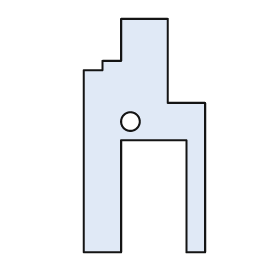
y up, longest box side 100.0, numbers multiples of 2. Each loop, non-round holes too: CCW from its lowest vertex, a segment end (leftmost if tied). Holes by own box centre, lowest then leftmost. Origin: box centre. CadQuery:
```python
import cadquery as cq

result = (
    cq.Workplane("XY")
    .moveTo(-26.0, -50.0)
    .lineTo(-10.0, -50.0)
    .lineTo(-10.0, -2.0)
    .lineTo(18.0, -2.0)
    .lineTo(18.0, -50.0)
    .lineTo(26.0, -50.0)
    .lineTo(26.0, 14.0)
    .lineTo(10.0, 14.0)
    .lineTo(10.0, 50.0)
    .lineTo(-10.0, 50.0)
    .lineTo(-10.0, 32.0)
    .lineTo(-18.0, 32.0)
    .lineTo(-18.0, 28.0)
    .lineTo(-26.0, 28.0)
    .close()
    .moveTo(-6.0, 6.0)
    .circle(4.0)
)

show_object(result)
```